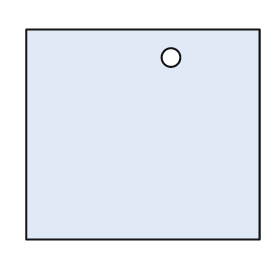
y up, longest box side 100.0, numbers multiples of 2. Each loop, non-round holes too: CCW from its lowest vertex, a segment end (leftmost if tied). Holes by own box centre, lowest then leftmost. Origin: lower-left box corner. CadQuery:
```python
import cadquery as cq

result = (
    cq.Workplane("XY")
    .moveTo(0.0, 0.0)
    .lineTo(100.0, 0.0)
    .lineTo(100.0, 90.0)
    .lineTo(0.0, 90.0)
    .close()
    .moveTo(62.0, 78.0)
    .circle(4.0)
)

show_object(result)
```